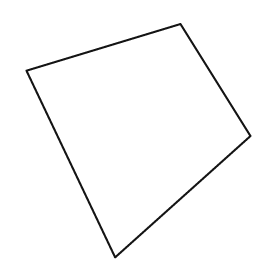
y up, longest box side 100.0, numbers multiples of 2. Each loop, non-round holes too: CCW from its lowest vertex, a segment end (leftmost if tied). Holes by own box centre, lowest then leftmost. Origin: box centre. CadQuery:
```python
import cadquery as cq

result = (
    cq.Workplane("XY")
    .moveTo(-10.0, -50.0)
    .lineTo(48.0, 2.0)
    .lineTo(18.0, 50.0)
    .lineTo(-48.0, 30.0)
    .close()
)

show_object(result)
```